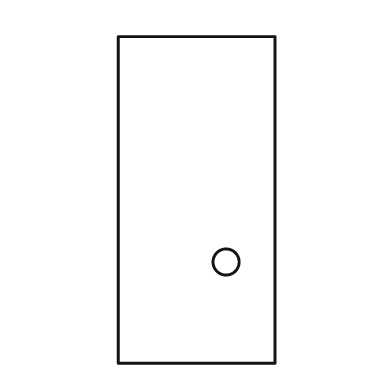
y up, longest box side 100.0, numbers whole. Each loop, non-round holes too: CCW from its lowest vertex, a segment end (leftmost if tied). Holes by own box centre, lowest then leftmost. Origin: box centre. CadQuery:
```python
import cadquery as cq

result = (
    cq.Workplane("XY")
    .moveTo(-24.0, -50.0)
    .lineTo(24.0, -50.0)
    .lineTo(24.0, 50.0)
    .lineTo(-24.0, 50.0)
    .close()
    .moveTo(9.0, -19.0)
    .circle(4.0)
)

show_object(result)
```